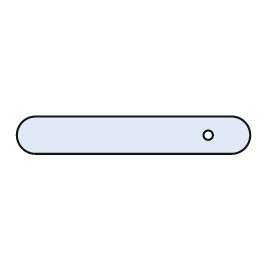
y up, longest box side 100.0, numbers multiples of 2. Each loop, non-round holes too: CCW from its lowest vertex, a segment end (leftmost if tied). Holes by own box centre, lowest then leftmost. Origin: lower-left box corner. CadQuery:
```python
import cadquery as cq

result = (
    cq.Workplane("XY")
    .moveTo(8.0, 0.0)
    .lineTo(92.0, 0.0)
    .threePointArc((100.0, 8.0), (92.0, 16.0))
    .lineTo(8.0, 16.0)
    .threePointArc((0.0, 8.0), (8.0, 0.0))
    .close()
    .moveTo(82.0, 8.0)
    .circle(2.0)
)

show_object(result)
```